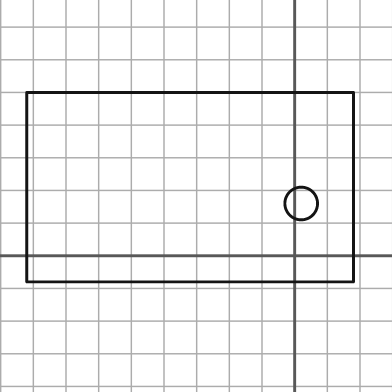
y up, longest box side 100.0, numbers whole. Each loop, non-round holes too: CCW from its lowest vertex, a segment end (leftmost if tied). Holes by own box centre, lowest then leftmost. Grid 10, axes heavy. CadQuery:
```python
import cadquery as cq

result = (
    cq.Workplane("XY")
    .moveTo(-82.0, -8.0)
    .lineTo(18.0, -8.0)
    .lineTo(18.0, 50.0)
    .lineTo(-82.0, 50.0)
    .close()
    .moveTo(2.0, 16.0)
    .circle(5.0)
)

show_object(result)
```